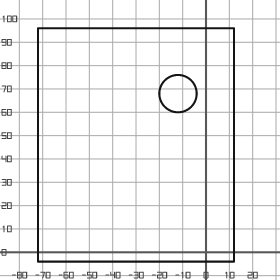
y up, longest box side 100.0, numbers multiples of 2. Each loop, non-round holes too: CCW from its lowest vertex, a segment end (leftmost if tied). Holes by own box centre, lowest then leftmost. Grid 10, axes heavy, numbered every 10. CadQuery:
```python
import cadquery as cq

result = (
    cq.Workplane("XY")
    .moveTo(-72.0, -4.0)
    .lineTo(12.0, -4.0)
    .lineTo(12.0, 96.0)
    .lineTo(-72.0, 96.0)
    .close()
    .moveTo(-12.0, 68.0)
    .circle(8.0)
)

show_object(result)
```